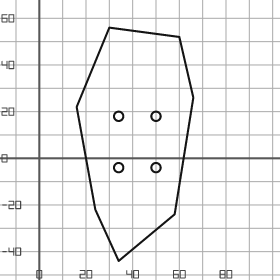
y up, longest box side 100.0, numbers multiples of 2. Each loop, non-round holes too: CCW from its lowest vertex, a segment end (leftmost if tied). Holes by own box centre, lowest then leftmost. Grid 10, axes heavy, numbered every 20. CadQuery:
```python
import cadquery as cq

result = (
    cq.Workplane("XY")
    .moveTo(34.0, -44.0)
    .lineTo(58.0, -24.0)
    .lineTo(66.0, 26.0)
    .lineTo(60.0, 52.0)
    .lineTo(30.0, 56.0)
    .lineTo(16.0, 22.0)
    .lineTo(24.0, -22.0)
    .close()
    .moveTo(34.0, -4.0)
    .circle(2.0)
    .moveTo(50.0, -4.0)
    .circle(2.0)
    .moveTo(34.0, 18.0)
    .circle(2.0)
    .moveTo(50.0, 18.0)
    .circle(2.0)
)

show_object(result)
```